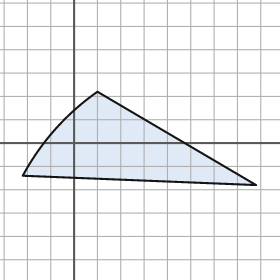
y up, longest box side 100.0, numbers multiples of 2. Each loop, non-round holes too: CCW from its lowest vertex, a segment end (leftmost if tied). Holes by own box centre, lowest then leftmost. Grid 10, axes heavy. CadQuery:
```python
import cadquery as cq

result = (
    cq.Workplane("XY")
    .moveTo(78.0, -18.0)
    .lineTo(10.0, 22.0)
    .threePointArc((-8.0, 6.0), (-22.0, -14.0))
    .close()
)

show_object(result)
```